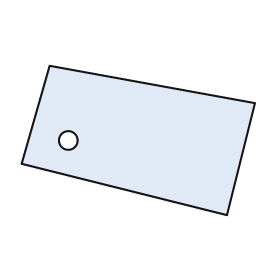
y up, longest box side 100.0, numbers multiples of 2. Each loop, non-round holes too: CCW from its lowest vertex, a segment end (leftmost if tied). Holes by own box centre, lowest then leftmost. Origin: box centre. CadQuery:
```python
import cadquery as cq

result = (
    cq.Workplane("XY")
    .moveTo(38.0, -32.0)
    .lineTo(50.0, 16.0)
    .lineTo(-38.0, 32.0)
    .lineTo(-50.0, -10.0)
    .close()
    .moveTo(-30.0, 0.0)
    .circle(4.0)
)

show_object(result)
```